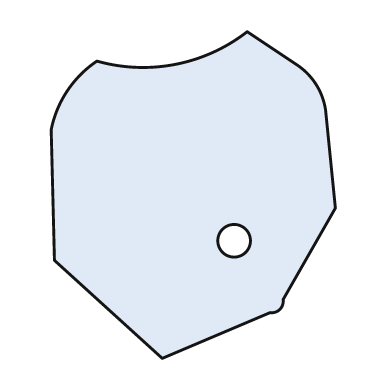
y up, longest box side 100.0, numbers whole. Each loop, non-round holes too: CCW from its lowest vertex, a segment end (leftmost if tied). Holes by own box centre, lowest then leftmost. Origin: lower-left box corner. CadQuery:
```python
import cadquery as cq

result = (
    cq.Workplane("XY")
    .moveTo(34.0, 0.0)
    .lineTo(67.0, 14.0)
    .threePointArc((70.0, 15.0), (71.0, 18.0))
    .lineTo(87.0, 46.0)
    .lineTo(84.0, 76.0)
    .threePointArc((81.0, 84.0), (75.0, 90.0))
    .lineTo(60.0, 100.0)
    .threePointArc((38.0, 90.0), (14.0, 91.0))
    .threePointArc((5.0, 82.0), (0.0, 70.0))
    .lineTo(1.0, 30.0)
    .close()
    .moveTo(56.0, 36.0)
    .circle(5.0)
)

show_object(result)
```